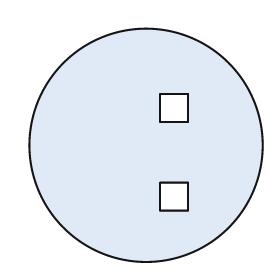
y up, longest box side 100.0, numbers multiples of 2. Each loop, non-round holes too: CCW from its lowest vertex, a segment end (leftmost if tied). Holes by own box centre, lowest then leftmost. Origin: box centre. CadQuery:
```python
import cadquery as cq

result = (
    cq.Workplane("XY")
    .moveTo(0.0, 0.0)
    .circle(50.0)
    .moveTo(6.0, -28.0)
    .lineTo(18.0, -28.0)
    .lineTo(18.0, -16.0)
    .lineTo(6.0, -16.0)
    .close()
    .moveTo(6.0, 10.0)
    .lineTo(18.0, 10.0)
    .lineTo(18.0, 22.0)
    .lineTo(6.0, 22.0)
    .close()
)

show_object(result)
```